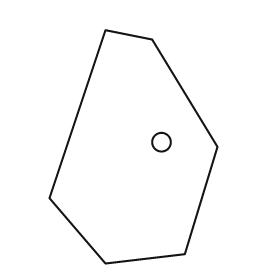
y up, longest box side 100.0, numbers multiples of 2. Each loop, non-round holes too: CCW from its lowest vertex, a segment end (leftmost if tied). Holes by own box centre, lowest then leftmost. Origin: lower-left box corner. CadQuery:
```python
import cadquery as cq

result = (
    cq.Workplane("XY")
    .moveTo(24.0, 0.0)
    .lineTo(58.0, 4.0)
    .lineTo(72.0, 50.0)
    .lineTo(44.0, 96.0)
    .lineTo(24.0, 100.0)
    .lineTo(0.0, 28.0)
    .close()
    .moveTo(48.0, 52.0)
    .circle(4.0)
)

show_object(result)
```